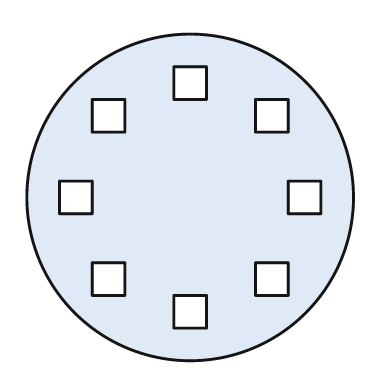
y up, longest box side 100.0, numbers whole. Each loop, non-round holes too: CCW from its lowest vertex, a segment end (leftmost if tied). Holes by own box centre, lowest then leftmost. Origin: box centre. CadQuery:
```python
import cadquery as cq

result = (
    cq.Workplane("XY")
    .moveTo(0.0, 0.0)
    .circle(50.0)
    .moveTo(-5.0, -40.0)
    .lineTo(5.0, -40.0)
    .lineTo(5.0, -30.0)
    .lineTo(-5.0, -30.0)
    .close()
    .moveTo(-30.0, -30.0)
    .lineTo(-20.0, -30.0)
    .lineTo(-20.0, -20.0)
    .lineTo(-30.0, -20.0)
    .close()
    .moveTo(20.0, -30.0)
    .lineTo(30.0, -30.0)
    .lineTo(30.0, -20.0)
    .lineTo(20.0, -20.0)
    .close()
    .moveTo(-40.0, -5.0)
    .lineTo(-30.0, -5.0)
    .lineTo(-30.0, 5.0)
    .lineTo(-40.0, 5.0)
    .close()
    .moveTo(30.0, -5.0)
    .lineTo(40.0, -5.0)
    .lineTo(40.0, 5.0)
    .lineTo(30.0, 5.0)
    .close()
    .moveTo(-30.0, 20.0)
    .lineTo(-20.0, 20.0)
    .lineTo(-20.0, 30.0)
    .lineTo(-30.0, 30.0)
    .close()
    .moveTo(20.0, 20.0)
    .lineTo(30.0, 20.0)
    .lineTo(30.0, 30.0)
    .lineTo(20.0, 30.0)
    .close()
    .moveTo(-5.0, 30.0)
    .lineTo(5.0, 30.0)
    .lineTo(5.0, 40.0)
    .lineTo(-5.0, 40.0)
    .close()
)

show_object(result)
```